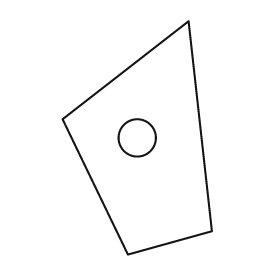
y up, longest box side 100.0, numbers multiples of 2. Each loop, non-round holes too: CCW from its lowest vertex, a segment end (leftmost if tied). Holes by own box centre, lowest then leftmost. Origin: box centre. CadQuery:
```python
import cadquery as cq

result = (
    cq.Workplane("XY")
    .moveTo(-4.0, -50.0)
    .lineTo(32.0, -40.0)
    .lineTo(22.0, 50.0)
    .lineTo(-32.0, 8.0)
    .close()
    .moveTo(0.0, 0.0)
    .circle(8.0)
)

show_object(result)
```